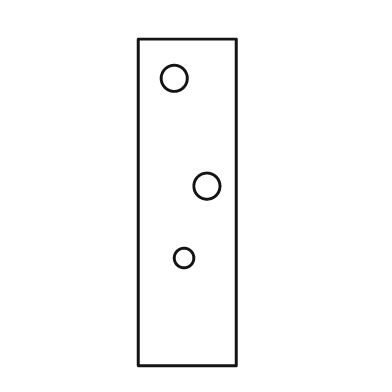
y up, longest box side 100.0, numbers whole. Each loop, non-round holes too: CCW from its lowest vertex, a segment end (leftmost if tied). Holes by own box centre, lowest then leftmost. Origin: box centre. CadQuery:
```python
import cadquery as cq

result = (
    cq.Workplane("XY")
    .moveTo(-15.0, -50.0)
    .lineTo(15.0, -50.0)
    .lineTo(15.0, 50.0)
    .lineTo(-15.0, 50.0)
    .close()
    .moveTo(-1.0, -17.0)
    .circle(3.0)
    .moveTo(6.0, 5.0)
    .circle(4.0)
    .moveTo(-4.0, 38.0)
    .circle(4.0)
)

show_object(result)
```